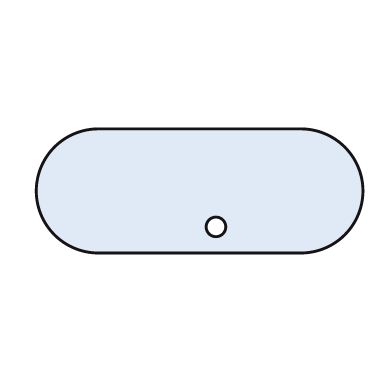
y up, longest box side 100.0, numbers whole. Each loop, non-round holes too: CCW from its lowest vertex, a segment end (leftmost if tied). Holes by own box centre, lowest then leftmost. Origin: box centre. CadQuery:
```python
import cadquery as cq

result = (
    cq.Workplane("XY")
    .moveTo(-31.0, -19.0)
    .lineTo(31.0, -19.0)
    .threePointArc((50.0, 0.0), (31.0, 19.0))
    .lineTo(-31.0, 19.0)
    .threePointArc((-50.0, 0.0), (-31.0, -19.0))
    .close()
    .moveTo(5.0, -11.0)
    .circle(3.0)
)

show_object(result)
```